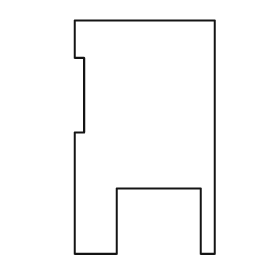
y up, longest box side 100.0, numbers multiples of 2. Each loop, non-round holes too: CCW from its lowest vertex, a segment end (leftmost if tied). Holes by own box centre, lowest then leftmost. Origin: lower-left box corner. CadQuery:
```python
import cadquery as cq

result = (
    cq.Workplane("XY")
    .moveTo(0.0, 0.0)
    .lineTo(18.0, 0.0)
    .lineTo(18.0, 28.0)
    .lineTo(54.0, 28.0)
    .lineTo(54.0, 0.0)
    .lineTo(60.0, 0.0)
    .lineTo(60.0, 100.0)
    .lineTo(0.0, 100.0)
    .lineTo(0.0, 84.0)
    .lineTo(4.0, 84.0)
    .lineTo(4.0, 52.0)
    .lineTo(0.0, 52.0)
    .close()
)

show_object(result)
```